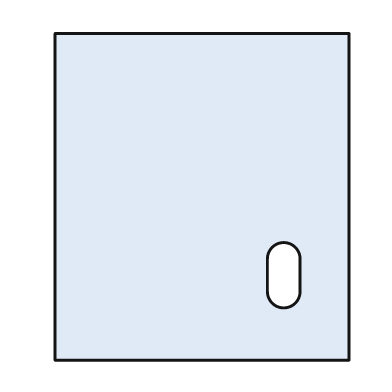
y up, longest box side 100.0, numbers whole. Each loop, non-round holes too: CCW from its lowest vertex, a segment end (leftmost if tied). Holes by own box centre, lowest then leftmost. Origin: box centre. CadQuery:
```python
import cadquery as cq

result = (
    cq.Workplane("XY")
    .moveTo(-45.0, -50.0)
    .lineTo(45.0, -50.0)
    .lineTo(45.0, 50.0)
    .lineTo(-45.0, 50.0)
    .close()
    .moveTo(20.0, -29.0)
    .threePointArc((25.0, -34.0), (30.0, -29.0))
    .lineTo(30.0, -19.0)
    .threePointArc((25.0, -14.0), (20.0, -19.0))
    .close()
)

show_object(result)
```